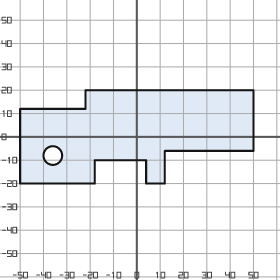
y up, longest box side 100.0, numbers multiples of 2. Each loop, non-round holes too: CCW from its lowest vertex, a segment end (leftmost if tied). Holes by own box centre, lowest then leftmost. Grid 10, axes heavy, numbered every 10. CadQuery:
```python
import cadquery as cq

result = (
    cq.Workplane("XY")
    .moveTo(-50.0, -20.0)
    .lineTo(-18.0, -20.0)
    .lineTo(-18.0, -10.0)
    .lineTo(4.0, -10.0)
    .lineTo(4.0, -20.0)
    .lineTo(12.0, -20.0)
    .lineTo(12.0, -6.0)
    .lineTo(50.0, -6.0)
    .lineTo(50.0, 20.0)
    .lineTo(-22.0, 20.0)
    .lineTo(-22.0, 12.0)
    .lineTo(-50.0, 12.0)
    .close()
    .moveTo(-36.0, -8.0)
    .circle(4.0)
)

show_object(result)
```